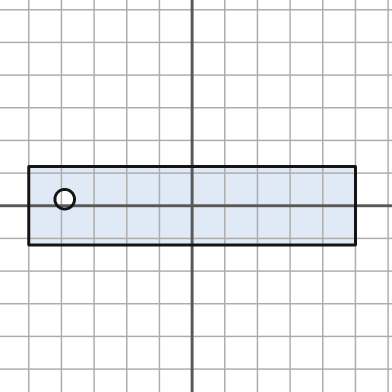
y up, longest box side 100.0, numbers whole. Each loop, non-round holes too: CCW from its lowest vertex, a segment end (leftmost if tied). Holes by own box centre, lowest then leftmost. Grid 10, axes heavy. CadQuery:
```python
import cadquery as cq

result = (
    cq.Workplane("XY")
    .moveTo(-50.0, -12.0)
    .lineTo(50.0, -12.0)
    .lineTo(50.0, 12.0)
    .lineTo(-50.0, 12.0)
    .close()
    .moveTo(-39.0, 2.0)
    .circle(3.0)
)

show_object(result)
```